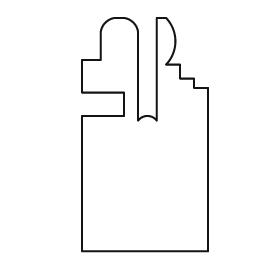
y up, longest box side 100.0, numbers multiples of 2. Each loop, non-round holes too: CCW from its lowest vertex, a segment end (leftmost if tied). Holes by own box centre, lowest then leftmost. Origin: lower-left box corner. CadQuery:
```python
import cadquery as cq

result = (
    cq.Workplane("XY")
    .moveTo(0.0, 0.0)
    .lineTo(54.0, 0.0)
    .lineTo(54.0, 70.0)
    .lineTo(48.0, 70.0)
    .lineTo(48.0, 74.0)
    .lineTo(42.0, 74.0)
    .lineTo(42.0, 80.0)
    .lineTo(36.0, 80.0)
    .threePointArc((40.0, 90.0), (36.0, 100.0))
    .lineTo(32.0, 100.0)
    .lineTo(32.0, 56.0)
    .threePointArc((28.0, 58.0), (24.0, 56.0))
    .lineTo(24.0, 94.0)
    .threePointArc((22.0, 98.0), (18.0, 100.0))
    .lineTo(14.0, 100.0)
    .threePointArc((10.0, 98.0), (8.0, 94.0))
    .lineTo(8.0, 82.0)
    .lineTo(0.0, 82.0)
    .lineTo(0.0, 68.0)
    .lineTo(18.0, 68.0)
    .lineTo(18.0, 58.0)
    .lineTo(0.0, 58.0)
    .close()
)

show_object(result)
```